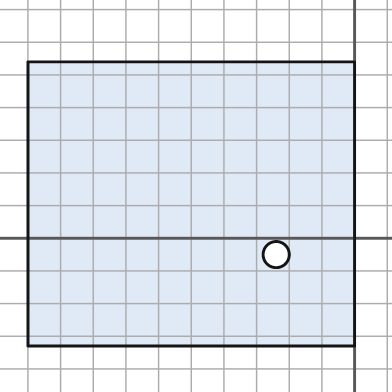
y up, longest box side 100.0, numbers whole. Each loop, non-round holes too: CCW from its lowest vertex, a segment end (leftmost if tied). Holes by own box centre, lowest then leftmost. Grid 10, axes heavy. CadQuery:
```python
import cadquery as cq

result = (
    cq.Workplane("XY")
    .moveTo(-100.0, -33.0)
    .lineTo(0.0, -33.0)
    .lineTo(0.0, 54.0)
    .lineTo(-100.0, 54.0)
    .close()
    .moveTo(-24.0, -5.0)
    .circle(4.0)
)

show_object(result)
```